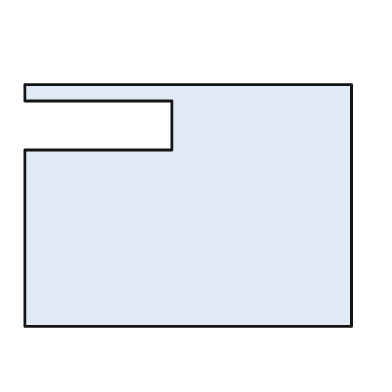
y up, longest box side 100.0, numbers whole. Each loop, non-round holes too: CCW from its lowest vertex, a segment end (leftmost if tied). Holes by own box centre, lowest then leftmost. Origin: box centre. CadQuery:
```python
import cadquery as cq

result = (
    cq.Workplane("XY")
    .moveTo(-50.0, -37.0)
    .lineTo(50.0, -37.0)
    .lineTo(50.0, 37.0)
    .lineTo(-50.0, 37.0)
    .lineTo(-50.0, 32.0)
    .lineTo(-5.0, 32.0)
    .lineTo(-5.0, 17.0)
    .lineTo(-50.0, 17.0)
    .close()
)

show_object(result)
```